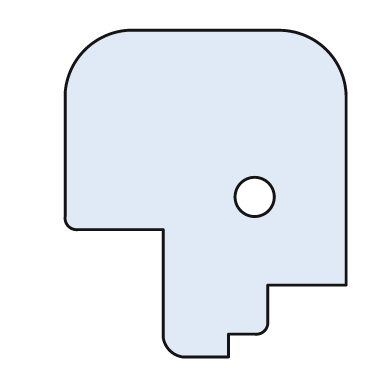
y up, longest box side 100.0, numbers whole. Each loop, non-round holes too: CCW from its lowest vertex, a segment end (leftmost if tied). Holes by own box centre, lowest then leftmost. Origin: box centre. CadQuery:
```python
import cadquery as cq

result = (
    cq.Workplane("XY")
    .moveTo(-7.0, -50.0)
    .lineTo(7.0, -50.0)
    .lineTo(7.0, -43.0)
    .lineTo(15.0, -43.0)
    .threePointArc((18.0, -42.0), (19.0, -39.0))
    .lineTo(19.0, -28.0)
    .lineTo(43.0, -28.0)
    .lineTo(43.0, 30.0)
    .threePointArc((37.0, 44.0), (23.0, 50.0))
    .lineTo(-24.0, 50.0)
    .threePointArc((-37.0, 44.0), (-43.0, 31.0))
    .lineTo(-43.0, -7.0)
    .threePointArc((-42.0, -10.0), (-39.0, -11.0))
    .lineTo(-13.0, -11.0)
    .lineTo(-13.0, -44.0)
    .threePointArc((-11.0, -48.0), (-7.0, -50.0))
    .close()
    .moveTo(15.0, -1.0)
    .circle(6.0)
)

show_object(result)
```